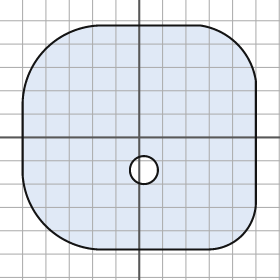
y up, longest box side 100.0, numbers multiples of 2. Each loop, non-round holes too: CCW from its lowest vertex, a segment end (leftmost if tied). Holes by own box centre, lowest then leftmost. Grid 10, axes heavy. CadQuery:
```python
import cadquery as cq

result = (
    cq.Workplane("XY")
    .moveTo(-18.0, -48.0)
    .lineTo(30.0, -48.0)
    .threePointArc((44.0, -42.0), (50.0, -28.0))
    .lineTo(50.0, 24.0)
    .threePointArc((42.0, 40.0), (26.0, 48.0))
    .lineTo(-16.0, 48.0)
    .threePointArc((-40.0, 38.0), (-50.0, 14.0))
    .lineTo(-50.0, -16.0)
    .threePointArc((-40.0, -38.0), (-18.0, -48.0))
    .close()
    .moveTo(2.0, -14.0)
    .circle(6.0)
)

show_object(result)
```